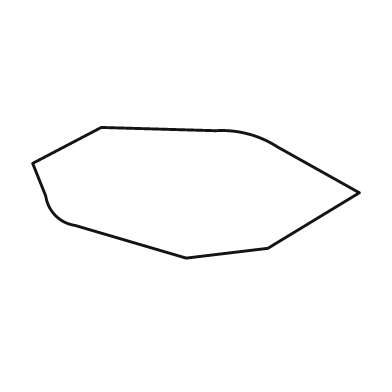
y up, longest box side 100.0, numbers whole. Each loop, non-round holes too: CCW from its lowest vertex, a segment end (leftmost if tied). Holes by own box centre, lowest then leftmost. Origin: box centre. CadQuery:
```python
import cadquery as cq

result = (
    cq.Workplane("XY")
    .moveTo(-3.0, -20.0)
    .lineTo(22.0, -17.0)
    .lineTo(50.0, 0.0)
    .lineTo(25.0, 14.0)
    .threePointArc((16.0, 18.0), (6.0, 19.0))
    .lineTo(-29.0, 20.0)
    .lineTo(-50.0, 9.0)
    .lineTo(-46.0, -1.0)
    .threePointArc((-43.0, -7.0), (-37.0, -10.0))
    .close()
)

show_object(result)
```